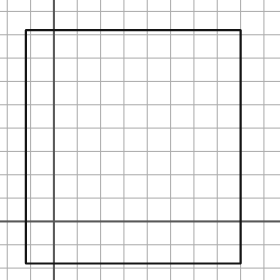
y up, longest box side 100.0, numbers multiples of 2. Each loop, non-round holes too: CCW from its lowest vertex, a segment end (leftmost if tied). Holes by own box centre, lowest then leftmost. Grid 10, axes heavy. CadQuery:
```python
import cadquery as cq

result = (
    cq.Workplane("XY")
    .moveTo(-12.0, -18.0)
    .lineTo(80.0, -18.0)
    .lineTo(80.0, 82.0)
    .lineTo(-12.0, 82.0)
    .close()
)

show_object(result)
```